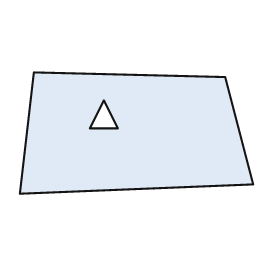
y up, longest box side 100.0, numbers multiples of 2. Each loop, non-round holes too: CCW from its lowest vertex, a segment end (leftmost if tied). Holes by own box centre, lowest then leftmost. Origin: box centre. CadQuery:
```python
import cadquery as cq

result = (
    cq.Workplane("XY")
    .moveTo(-50.0, -26.0)
    .lineTo(50.0, -22.0)
    .lineTo(38.0, 24.0)
    .lineTo(-44.0, 26.0)
    .close()
    .moveTo(-20.0, 2.0)
    .lineTo(-8.0, 2.0)
    .lineTo(-14.0, 14.0)
    .close()
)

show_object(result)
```